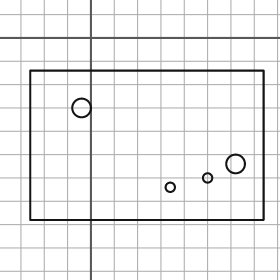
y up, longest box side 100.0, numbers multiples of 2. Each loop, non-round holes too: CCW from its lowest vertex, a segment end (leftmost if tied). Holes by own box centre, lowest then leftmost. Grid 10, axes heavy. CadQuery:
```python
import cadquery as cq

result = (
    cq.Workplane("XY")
    .moveTo(-26.0, -78.0)
    .lineTo(74.0, -78.0)
    .lineTo(74.0, -14.0)
    .lineTo(-26.0, -14.0)
    .close()
    .moveTo(34.0, -64.0)
    .circle(2.0)
    .moveTo(50.0, -60.0)
    .circle(2.0)
    .moveTo(62.0, -54.0)
    .circle(4.0)
    .moveTo(-4.0, -30.0)
    .circle(4.0)
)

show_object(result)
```